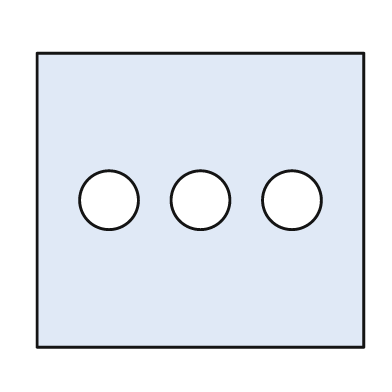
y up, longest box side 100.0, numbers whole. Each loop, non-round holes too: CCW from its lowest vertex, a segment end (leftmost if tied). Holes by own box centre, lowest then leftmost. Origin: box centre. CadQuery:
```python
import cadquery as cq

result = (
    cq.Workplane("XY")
    .moveTo(-50.0, -45.0)
    .lineTo(50.0, -45.0)
    .lineTo(50.0, 45.0)
    .lineTo(-50.0, 45.0)
    .close()
    .moveTo(-28.0, 0.0)
    .circle(9.0)
    .moveTo(0.0, 0.0)
    .circle(9.0)
    .moveTo(28.0, 0.0)
    .circle(9.0)
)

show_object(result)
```